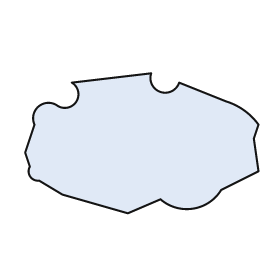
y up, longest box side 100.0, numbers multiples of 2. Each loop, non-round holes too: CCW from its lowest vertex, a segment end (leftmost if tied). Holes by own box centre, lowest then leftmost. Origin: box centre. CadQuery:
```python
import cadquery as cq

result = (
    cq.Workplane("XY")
    .moveTo(-6.0, -30.0)
    .lineTo(8.0, -24.0)
    .threePointArc((22.0, -28.0), (34.0, -20.0))
    .lineTo(50.0, -12.0)
    .lineTo(48.0, 2.0)
    .lineTo(50.0, 8.0)
    .threePointArc((44.0, 14.0), (36.0, 18.0))
    .lineTo(16.0, 26.0)
    .threePointArc((8.0, 22.0), (4.0, 30.0))
    .lineTo(-30.0, 26.0)
    .threePointArc((-28.0, 18.0), (-36.0, 16.0))
    .threePointArc((-44.0, 16.0), (-46.0, 8.0))
    .lineTo(-50.0, -4.0)
    .lineTo(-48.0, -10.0)
    .threePointArc((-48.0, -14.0), (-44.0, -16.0))
    .lineTo(-34.0, -22.0)
    .close()
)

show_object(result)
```